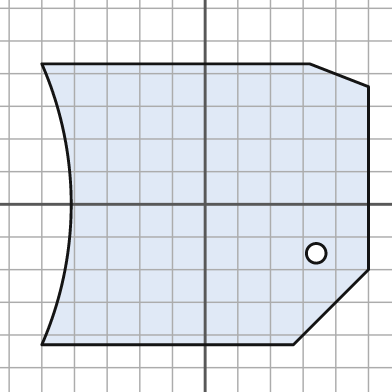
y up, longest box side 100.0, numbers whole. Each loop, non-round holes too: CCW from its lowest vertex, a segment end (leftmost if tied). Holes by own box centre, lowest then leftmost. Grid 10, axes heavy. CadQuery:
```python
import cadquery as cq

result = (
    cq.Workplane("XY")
    .moveTo(-50.0, -43.0)
    .lineTo(27.0, -43.0)
    .lineTo(50.0, -20.0)
    .lineTo(50.0, 36.0)
    .lineTo(32.0, 43.0)
    .lineTo(-50.0, 43.0)
    .threePointArc((-41.0, 0.0), (-50.0, -43.0))
    .close()
    .moveTo(34.0, -15.0)
    .circle(3.0)
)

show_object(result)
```